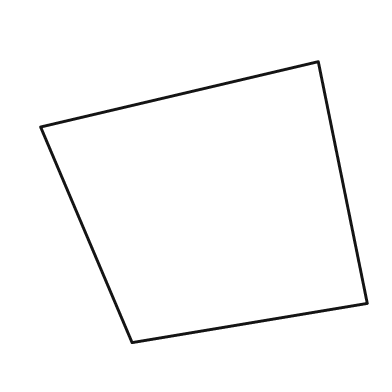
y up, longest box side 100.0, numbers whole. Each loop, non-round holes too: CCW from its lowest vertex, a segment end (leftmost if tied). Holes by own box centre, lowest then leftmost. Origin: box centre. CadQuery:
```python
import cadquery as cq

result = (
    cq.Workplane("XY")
    .moveTo(-22.0, -43.0)
    .lineTo(50.0, -31.0)
    .lineTo(35.0, 43.0)
    .lineTo(-50.0, 23.0)
    .close()
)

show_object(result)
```